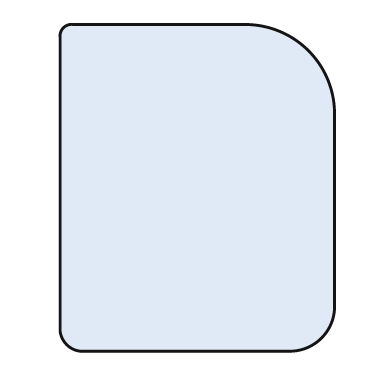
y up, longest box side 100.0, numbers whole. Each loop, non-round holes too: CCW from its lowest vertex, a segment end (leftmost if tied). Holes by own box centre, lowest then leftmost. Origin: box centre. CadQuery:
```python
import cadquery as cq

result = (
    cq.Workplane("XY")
    .moveTo(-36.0, -50.0)
    .lineTo(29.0, -50.0)
    .threePointArc((38.0, -46.0), (42.0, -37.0))
    .lineTo(42.0, 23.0)
    .threePointArc((34.0, 42.0), (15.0, 50.0))
    .lineTo(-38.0, 50.0)
    .threePointArc((-41.0, 49.0), (-42.0, 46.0))
    .lineTo(-42.0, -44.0)
    .threePointArc((-40.0, -48.0), (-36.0, -50.0))
    .close()
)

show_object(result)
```